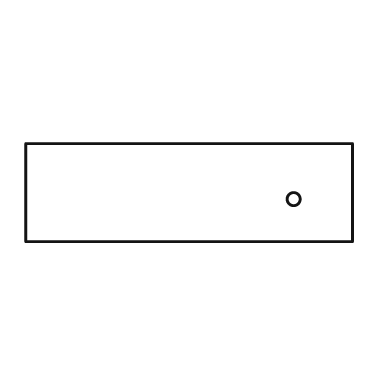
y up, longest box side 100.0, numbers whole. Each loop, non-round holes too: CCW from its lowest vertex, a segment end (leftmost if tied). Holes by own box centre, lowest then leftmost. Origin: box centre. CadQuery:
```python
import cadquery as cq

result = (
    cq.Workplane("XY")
    .moveTo(-50.0, -15.0)
    .lineTo(50.0, -15.0)
    .lineTo(50.0, 15.0)
    .lineTo(-50.0, 15.0)
    .close()
    .moveTo(32.0, -2.0)
    .circle(2.0)
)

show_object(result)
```